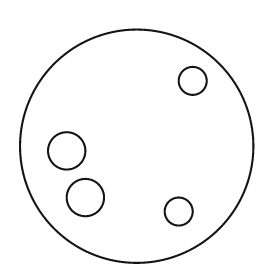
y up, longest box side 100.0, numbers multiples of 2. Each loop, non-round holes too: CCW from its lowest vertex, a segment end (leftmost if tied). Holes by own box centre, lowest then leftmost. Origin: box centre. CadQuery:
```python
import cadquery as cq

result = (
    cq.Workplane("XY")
    .moveTo(0.0, 0.0)
    .circle(50.0)
    .moveTo(18.0, -28.0)
    .circle(6.0)
    .moveTo(-22.0, -22.0)
    .circle(8.0)
    .moveTo(-30.0, -2.0)
    .circle(8.0)
    .moveTo(24.0, 28.0)
    .circle(6.0)
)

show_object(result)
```